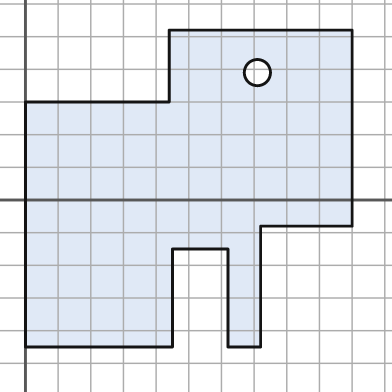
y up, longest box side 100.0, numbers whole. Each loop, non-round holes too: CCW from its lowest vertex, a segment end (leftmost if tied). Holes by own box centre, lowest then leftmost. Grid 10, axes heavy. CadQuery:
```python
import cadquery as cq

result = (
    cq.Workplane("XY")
    .moveTo(0.0, -45.0)
    .lineTo(45.0, -45.0)
    .lineTo(45.0, -15.0)
    .lineTo(62.0, -15.0)
    .lineTo(62.0, -45.0)
    .lineTo(72.0, -45.0)
    .lineTo(72.0, -8.0)
    .lineTo(100.0, -8.0)
    .lineTo(100.0, 52.0)
    .lineTo(44.0, 52.0)
    .lineTo(44.0, 30.0)
    .lineTo(0.0, 30.0)
    .close()
    .moveTo(71.0, 39.0)
    .circle(4.0)
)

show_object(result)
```